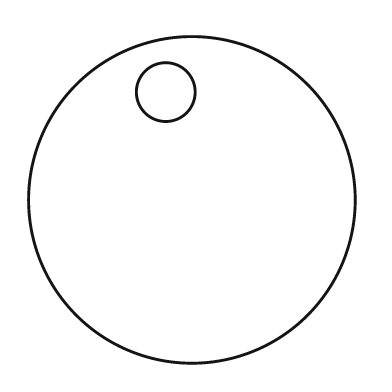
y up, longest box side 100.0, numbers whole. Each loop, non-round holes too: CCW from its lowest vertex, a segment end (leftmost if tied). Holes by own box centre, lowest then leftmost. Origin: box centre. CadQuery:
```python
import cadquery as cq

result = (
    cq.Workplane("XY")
    .moveTo(0.0, 0.0)
    .circle(50.0)
    .moveTo(-8.0, 33.0)
    .circle(9.0)
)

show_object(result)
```